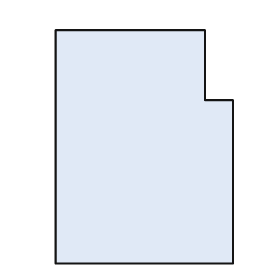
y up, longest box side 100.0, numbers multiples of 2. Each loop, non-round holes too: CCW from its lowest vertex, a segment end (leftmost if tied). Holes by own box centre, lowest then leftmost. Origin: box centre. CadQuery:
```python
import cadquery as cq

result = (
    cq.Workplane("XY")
    .moveTo(-38.0, -50.0)
    .lineTo(38.0, -50.0)
    .lineTo(38.0, 20.0)
    .lineTo(26.0, 20.0)
    .lineTo(26.0, 50.0)
    .lineTo(-38.0, 50.0)
    .close()
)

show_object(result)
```